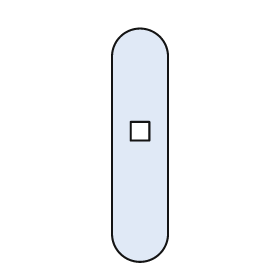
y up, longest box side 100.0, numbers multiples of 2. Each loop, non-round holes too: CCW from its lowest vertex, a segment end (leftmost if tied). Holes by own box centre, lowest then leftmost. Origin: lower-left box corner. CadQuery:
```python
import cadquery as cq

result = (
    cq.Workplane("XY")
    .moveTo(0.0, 12.0)
    .threePointArc((12.0, 0.0), (24.0, 12.0))
    .lineTo(24.0, 88.0)
    .threePointArc((12.0, 100.0), (0.0, 88.0))
    .close()
    .moveTo(8.0, 52.0)
    .lineTo(16.0, 52.0)
    .lineTo(16.0, 60.0)
    .lineTo(8.0, 60.0)
    .close()
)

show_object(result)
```